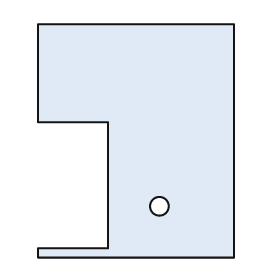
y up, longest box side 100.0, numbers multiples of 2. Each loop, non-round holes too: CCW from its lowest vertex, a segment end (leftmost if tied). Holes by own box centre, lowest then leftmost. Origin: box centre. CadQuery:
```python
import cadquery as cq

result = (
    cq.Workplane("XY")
    .moveTo(-42.0, -50.0)
    .lineTo(42.0, -50.0)
    .lineTo(42.0, 50.0)
    .lineTo(-42.0, 50.0)
    .lineTo(-42.0, 8.0)
    .lineTo(-12.0, 8.0)
    .lineTo(-12.0, -46.0)
    .lineTo(-42.0, -46.0)
    .close()
    .moveTo(10.0, -28.0)
    .circle(4.0)
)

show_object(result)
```